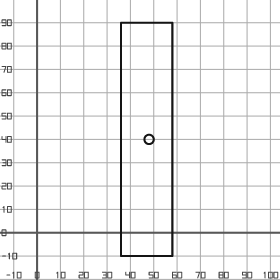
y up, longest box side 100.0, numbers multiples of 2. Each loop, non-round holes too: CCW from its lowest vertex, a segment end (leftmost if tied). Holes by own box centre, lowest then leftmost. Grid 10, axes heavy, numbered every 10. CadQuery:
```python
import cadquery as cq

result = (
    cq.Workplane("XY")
    .moveTo(36.0, -10.0)
    .lineTo(58.0, -10.0)
    .lineTo(58.0, 90.0)
    .lineTo(36.0, 90.0)
    .close()
    .moveTo(48.0, 40.0)
    .circle(2.0)
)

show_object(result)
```